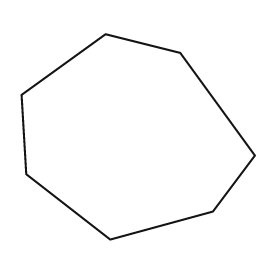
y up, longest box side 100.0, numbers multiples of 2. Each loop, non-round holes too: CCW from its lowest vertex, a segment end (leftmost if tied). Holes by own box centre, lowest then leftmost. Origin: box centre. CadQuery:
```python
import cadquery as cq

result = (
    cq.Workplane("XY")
    .moveTo(-12.0, -44.0)
    .lineTo(32.0, -32.0)
    .lineTo(50.0, -8.0)
    .lineTo(18.0, 36.0)
    .lineTo(-14.0, 44.0)
    .lineTo(-50.0, 18.0)
    .lineTo(-48.0, -16.0)
    .close()
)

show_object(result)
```